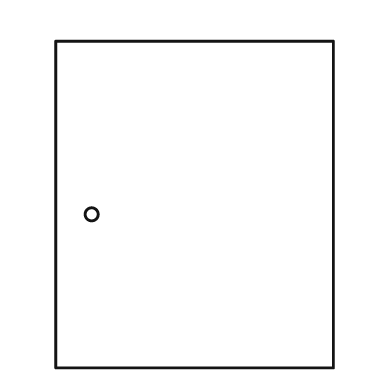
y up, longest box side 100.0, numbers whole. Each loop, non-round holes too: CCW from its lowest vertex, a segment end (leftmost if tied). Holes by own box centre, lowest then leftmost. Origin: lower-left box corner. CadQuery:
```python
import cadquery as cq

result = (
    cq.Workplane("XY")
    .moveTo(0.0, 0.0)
    .lineTo(85.0, 0.0)
    .lineTo(85.0, 100.0)
    .lineTo(0.0, 100.0)
    .close()
    .moveTo(11.0, 47.0)
    .circle(2.0)
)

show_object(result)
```